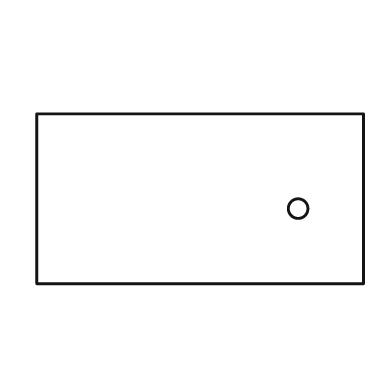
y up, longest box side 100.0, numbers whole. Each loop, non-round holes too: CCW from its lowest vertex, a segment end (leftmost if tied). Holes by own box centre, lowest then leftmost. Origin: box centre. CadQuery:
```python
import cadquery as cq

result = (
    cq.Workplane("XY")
    .moveTo(-50.0, -26.0)
    .lineTo(50.0, -26.0)
    .lineTo(50.0, 26.0)
    .lineTo(-50.0, 26.0)
    .close()
    .moveTo(30.0, -3.0)
    .circle(3.0)
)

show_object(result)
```